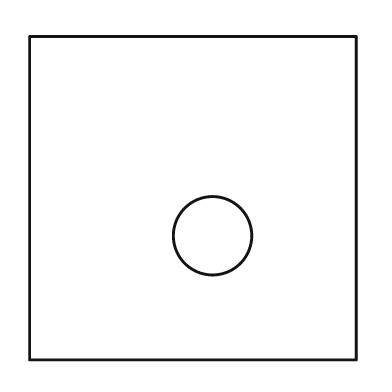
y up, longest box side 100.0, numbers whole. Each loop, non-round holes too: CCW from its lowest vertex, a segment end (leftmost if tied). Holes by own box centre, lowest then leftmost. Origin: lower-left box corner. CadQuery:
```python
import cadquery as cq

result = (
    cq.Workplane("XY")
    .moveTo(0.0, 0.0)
    .lineTo(100.0, 0.0)
    .lineTo(100.0, 99.0)
    .lineTo(0.0, 99.0)
    .close()
    .moveTo(56.0, 38.0)
    .circle(12.0)
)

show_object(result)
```